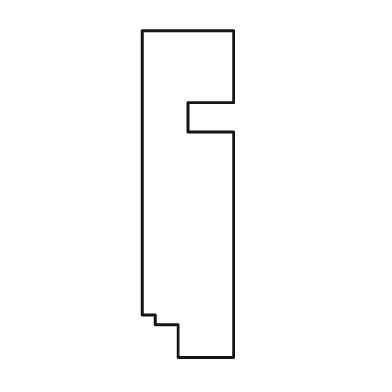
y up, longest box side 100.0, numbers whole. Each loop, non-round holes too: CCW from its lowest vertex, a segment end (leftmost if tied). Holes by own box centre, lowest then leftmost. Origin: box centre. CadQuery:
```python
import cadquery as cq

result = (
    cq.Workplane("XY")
    .moveTo(-3.0, -50.0)
    .lineTo(14.0, -50.0)
    .lineTo(14.0, 19.0)
    .lineTo(0.0, 19.0)
    .lineTo(0.0, 28.0)
    .lineTo(14.0, 28.0)
    .lineTo(14.0, 50.0)
    .lineTo(-14.0, 50.0)
    .lineTo(-14.0, -37.0)
    .lineTo(-10.0, -37.0)
    .lineTo(-10.0, -40.0)
    .lineTo(-3.0, -40.0)
    .close()
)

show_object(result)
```